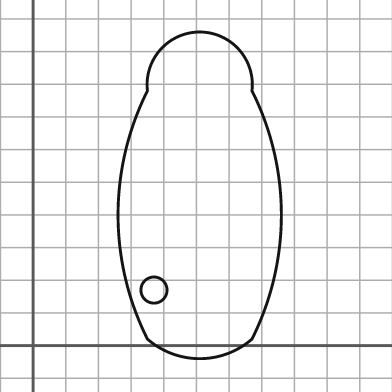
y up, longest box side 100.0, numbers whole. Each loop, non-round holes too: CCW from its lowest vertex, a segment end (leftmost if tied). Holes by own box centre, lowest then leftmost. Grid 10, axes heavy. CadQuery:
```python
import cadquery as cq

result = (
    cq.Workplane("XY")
    .moveTo(35.0, 2.0)
    .threePointArc((51.0, -4.0), (67.0, 2.0))
    .threePointArc((76.0, 40.0), (67.0, 78.0))
    .threePointArc((51.0, 96.0), (35.0, 78.0))
    .threePointArc((26.0, 40.0), (35.0, 2.0))
    .close()
    .moveTo(37.0, 17.0)
    .circle(4.0)
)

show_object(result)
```